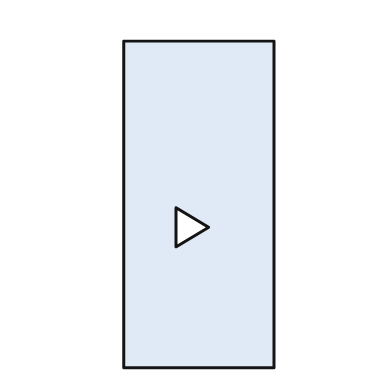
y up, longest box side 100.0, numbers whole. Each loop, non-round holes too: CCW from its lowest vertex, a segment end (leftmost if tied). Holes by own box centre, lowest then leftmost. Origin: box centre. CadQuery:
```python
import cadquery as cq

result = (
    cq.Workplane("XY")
    .moveTo(-23.0, -50.0)
    .lineTo(23.0, -50.0)
    .lineTo(23.0, 50.0)
    .lineTo(-23.0, 50.0)
    .close()
    .moveTo(-7.0, -13.0)
    .lineTo(3.0, -7.0)
    .lineTo(-7.0, -1.0)
    .close()
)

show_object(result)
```